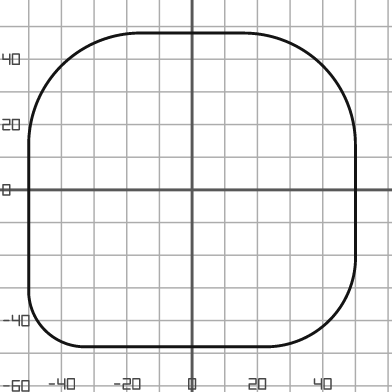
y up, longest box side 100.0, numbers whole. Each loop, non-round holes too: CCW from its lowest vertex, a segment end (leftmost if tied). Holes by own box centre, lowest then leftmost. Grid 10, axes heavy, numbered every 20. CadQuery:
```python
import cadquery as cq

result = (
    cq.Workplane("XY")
    .moveTo(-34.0, -48.0)
    .lineTo(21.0, -48.0)
    .threePointArc((42.0, -40.0), (50.0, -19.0))
    .lineTo(50.0, 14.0)
    .threePointArc((40.0, 38.0), (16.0, 48.0))
    .lineTo(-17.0, 48.0)
    .threePointArc((-40.0, 38.0), (-50.0, 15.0))
    .lineTo(-50.0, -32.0)
    .threePointArc((-45.0, -43.0), (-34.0, -48.0))
    .close()
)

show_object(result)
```